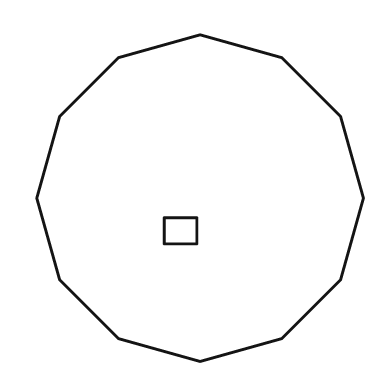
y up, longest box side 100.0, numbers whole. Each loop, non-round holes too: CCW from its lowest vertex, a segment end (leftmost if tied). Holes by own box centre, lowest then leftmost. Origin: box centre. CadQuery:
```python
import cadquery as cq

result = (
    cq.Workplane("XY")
    .moveTo(0.0, -50.0)
    .lineTo(25.0, -43.0)
    .lineTo(43.0, -25.0)
    .lineTo(50.0, 0.0)
    .lineTo(43.0, 25.0)
    .lineTo(25.0, 43.0)
    .lineTo(0.0, 50.0)
    .lineTo(-25.0, 43.0)
    .lineTo(-43.0, 25.0)
    .lineTo(-50.0, 0.0)
    .lineTo(-43.0, -25.0)
    .lineTo(-25.0, -43.0)
    .close()
    .moveTo(-11.0, -14.0)
    .lineTo(-1.0, -14.0)
    .lineTo(-1.0, -6.0)
    .lineTo(-11.0, -6.0)
    .close()
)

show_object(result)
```